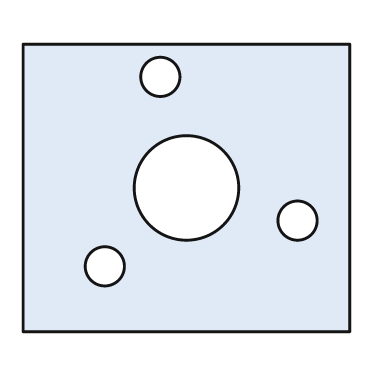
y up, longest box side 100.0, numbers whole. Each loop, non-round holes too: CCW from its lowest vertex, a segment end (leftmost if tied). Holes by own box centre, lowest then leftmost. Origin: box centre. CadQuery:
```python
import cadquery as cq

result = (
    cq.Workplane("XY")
    .moveTo(-50.0, -44.0)
    .lineTo(50.0, -44.0)
    .lineTo(50.0, 44.0)
    .lineTo(-50.0, 44.0)
    .close()
    .moveTo(-25.0, -24.0)
    .circle(6.0)
    .moveTo(34.0, -10.0)
    .circle(6.0)
    .moveTo(0.0, 0.0)
    .circle(16.0)
    .moveTo(-8.0, 34.0)
    .circle(6.0)
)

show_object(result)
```